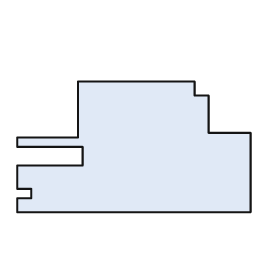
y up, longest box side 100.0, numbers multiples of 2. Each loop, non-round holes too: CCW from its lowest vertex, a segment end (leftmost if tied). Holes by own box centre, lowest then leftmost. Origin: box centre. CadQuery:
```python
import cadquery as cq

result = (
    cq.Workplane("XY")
    .moveTo(-50.0, -28.0)
    .lineTo(50.0, -28.0)
    .lineTo(50.0, 6.0)
    .lineTo(32.0, 6.0)
    .lineTo(32.0, 22.0)
    .lineTo(26.0, 22.0)
    .lineTo(26.0, 28.0)
    .lineTo(-24.0, 28.0)
    .lineTo(-24.0, 4.0)
    .lineTo(-50.0, 4.0)
    .lineTo(-50.0, 0.0)
    .lineTo(-22.0, 0.0)
    .lineTo(-22.0, -8.0)
    .lineTo(-50.0, -8.0)
    .lineTo(-50.0, -18.0)
    .lineTo(-44.0, -18.0)
    .lineTo(-44.0, -22.0)
    .lineTo(-50.0, -22.0)
    .close()
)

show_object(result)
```